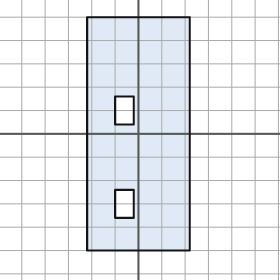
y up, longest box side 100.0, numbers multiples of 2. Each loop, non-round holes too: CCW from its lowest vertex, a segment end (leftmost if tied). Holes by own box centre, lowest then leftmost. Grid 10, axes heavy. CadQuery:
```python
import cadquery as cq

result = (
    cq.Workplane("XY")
    .moveTo(-22.0, -50.0)
    .lineTo(22.0, -50.0)
    .lineTo(22.0, 50.0)
    .lineTo(-22.0, 50.0)
    .close()
    .moveTo(-10.0, -36.0)
    .lineTo(-2.0, -36.0)
    .lineTo(-2.0, -24.0)
    .lineTo(-10.0, -24.0)
    .close()
    .moveTo(-10.0, 4.0)
    .lineTo(-2.0, 4.0)
    .lineTo(-2.0, 16.0)
    .lineTo(-10.0, 16.0)
    .close()
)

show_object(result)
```